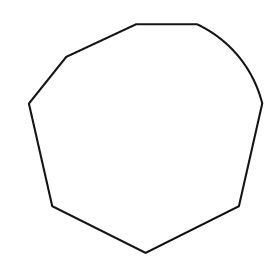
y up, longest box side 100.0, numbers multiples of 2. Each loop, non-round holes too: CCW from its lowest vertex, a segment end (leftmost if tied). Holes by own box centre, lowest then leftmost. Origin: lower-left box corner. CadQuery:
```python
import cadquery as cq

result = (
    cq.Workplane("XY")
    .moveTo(50.0, 0.0)
    .lineTo(90.0, 20.0)
    .lineTo(100.0, 64.0)
    .threePointArc((90.0, 84.0), (72.0, 98.0))
    .lineTo(46.0, 98.0)
    .lineTo(16.0, 84.0)
    .lineTo(0.0, 64.0)
    .lineTo(10.0, 20.0)
    .close()
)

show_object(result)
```